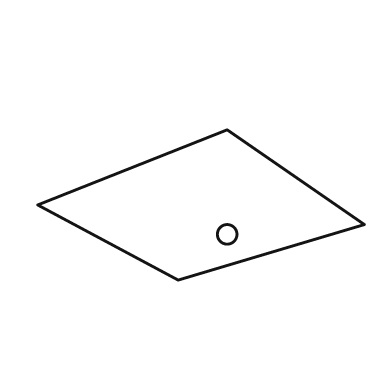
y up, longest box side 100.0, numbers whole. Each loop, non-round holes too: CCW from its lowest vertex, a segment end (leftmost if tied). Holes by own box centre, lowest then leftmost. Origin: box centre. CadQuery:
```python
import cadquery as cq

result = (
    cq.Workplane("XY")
    .moveTo(-7.0, -23.0)
    .lineTo(50.0, -6.0)
    .lineTo(8.0, 23.0)
    .lineTo(-50.0, 0.0)
    .close()
    .moveTo(8.0, -9.0)
    .circle(3.0)
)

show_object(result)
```